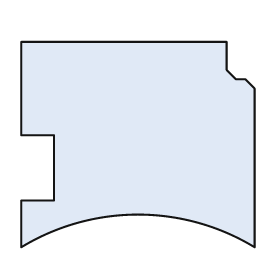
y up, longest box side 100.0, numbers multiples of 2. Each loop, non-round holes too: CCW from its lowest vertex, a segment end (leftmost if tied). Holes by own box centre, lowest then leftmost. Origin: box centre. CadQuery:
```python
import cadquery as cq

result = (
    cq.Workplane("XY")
    .moveTo(-50.0, -44.0)
    .threePointArc((0.0, -30.0), (50.0, -44.0))
    .lineTo(50.0, 24.0)
    .lineTo(46.0, 28.0)
    .lineTo(42.0, 28.0)
    .lineTo(38.0, 32.0)
    .lineTo(38.0, 44.0)
    .lineTo(-50.0, 44.0)
    .lineTo(-50.0, 4.0)
    .lineTo(-36.0, 4.0)
    .lineTo(-36.0, -24.0)
    .lineTo(-50.0, -24.0)
    .close()
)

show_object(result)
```